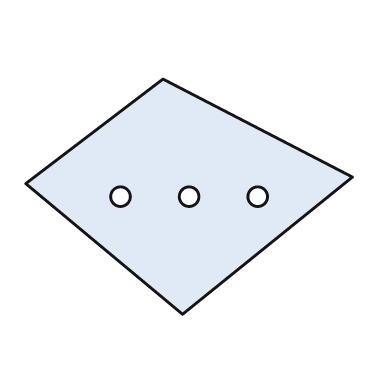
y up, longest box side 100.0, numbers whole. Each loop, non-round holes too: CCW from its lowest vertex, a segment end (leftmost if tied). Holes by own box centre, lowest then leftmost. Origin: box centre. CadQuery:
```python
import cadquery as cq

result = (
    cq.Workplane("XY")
    .moveTo(-2.0, -36.0)
    .lineTo(50.0, 6.0)
    .lineTo(-8.0, 36.0)
    .lineTo(-50.0, 4.0)
    .close()
    .moveTo(-21.0, 0.0)
    .circle(3.0)
    .moveTo(0.0, 0.0)
    .circle(3.0)
    .moveTo(21.0, 0.0)
    .circle(3.0)
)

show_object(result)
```